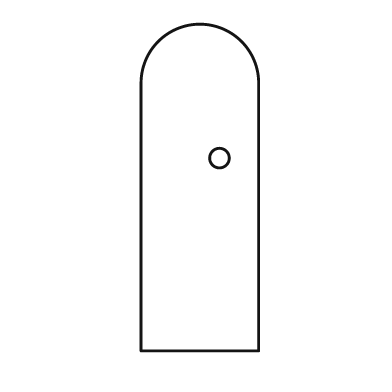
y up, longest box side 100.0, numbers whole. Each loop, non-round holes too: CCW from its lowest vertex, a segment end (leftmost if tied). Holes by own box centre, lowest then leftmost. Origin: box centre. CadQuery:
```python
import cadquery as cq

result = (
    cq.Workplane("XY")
    .moveTo(-18.0, -50.0)
    .lineTo(18.0, -50.0)
    .lineTo(18.0, 32.0)
    .threePointArc((0.0, 50.0), (-18.0, 32.0))
    .close()
    .moveTo(6.0, 9.0)
    .circle(3.0)
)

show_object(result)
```